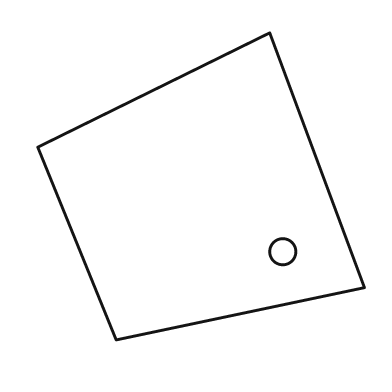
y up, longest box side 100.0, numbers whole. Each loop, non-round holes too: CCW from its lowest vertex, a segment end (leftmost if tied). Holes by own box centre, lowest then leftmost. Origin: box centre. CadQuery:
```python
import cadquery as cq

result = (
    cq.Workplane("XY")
    .moveTo(-26.0, -47.0)
    .lineTo(50.0, -31.0)
    .lineTo(21.0, 47.0)
    .lineTo(-50.0, 12.0)
    .close()
    .moveTo(25.0, -20.0)
    .circle(4.0)
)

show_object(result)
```